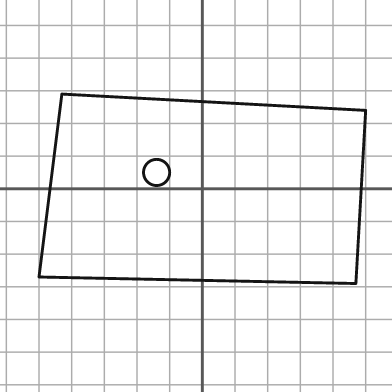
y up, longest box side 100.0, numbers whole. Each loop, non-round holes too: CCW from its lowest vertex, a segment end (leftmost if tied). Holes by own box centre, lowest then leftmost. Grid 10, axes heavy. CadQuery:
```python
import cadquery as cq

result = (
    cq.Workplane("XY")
    .moveTo(47.0, -29.0)
    .lineTo(50.0, 24.0)
    .lineTo(-43.0, 29.0)
    .lineTo(-50.0, -27.0)
    .close()
    .moveTo(-14.0, 5.0)
    .circle(4.0)
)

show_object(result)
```